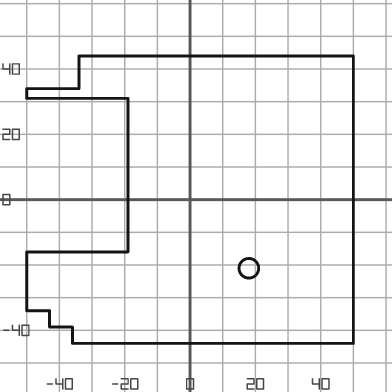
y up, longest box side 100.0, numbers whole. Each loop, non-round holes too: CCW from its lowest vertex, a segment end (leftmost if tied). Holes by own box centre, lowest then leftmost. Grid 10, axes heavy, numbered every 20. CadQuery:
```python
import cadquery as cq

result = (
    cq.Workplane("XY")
    .moveTo(-36.0, -44.0)
    .lineTo(50.0, -44.0)
    .lineTo(50.0, 44.0)
    .lineTo(-34.0, 44.0)
    .lineTo(-34.0, 34.0)
    .lineTo(-50.0, 34.0)
    .lineTo(-50.0, 31.0)
    .lineTo(-19.0, 31.0)
    .lineTo(-19.0, -16.0)
    .lineTo(-50.0, -16.0)
    .lineTo(-50.0, -34.0)
    .lineTo(-43.0, -34.0)
    .lineTo(-43.0, -39.0)
    .lineTo(-36.0, -39.0)
    .close()
    .moveTo(18.0, -21.0)
    .circle(3.0)
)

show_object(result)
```